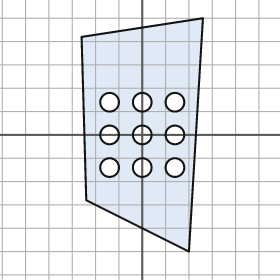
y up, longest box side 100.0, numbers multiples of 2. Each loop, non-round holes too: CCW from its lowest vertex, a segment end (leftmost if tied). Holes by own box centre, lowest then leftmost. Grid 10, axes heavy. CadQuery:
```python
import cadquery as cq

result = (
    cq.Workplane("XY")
    .moveTo(20.0, -50.0)
    .lineTo(26.0, 50.0)
    .lineTo(-26.0, 42.0)
    .lineTo(-24.0, -28.0)
    .close()
    .moveTo(-14.0, -14.0)
    .circle(4.0)
    .moveTo(0.0, -14.0)
    .circle(4.0)
    .moveTo(14.0, -14.0)
    .circle(4.0)
    .moveTo(-14.0, 0.0)
    .circle(4.0)
    .moveTo(0.0, 0.0)
    .circle(4.0)
    .moveTo(14.0, 0.0)
    .circle(4.0)
    .moveTo(-14.0, 14.0)
    .circle(4.0)
    .moveTo(0.0, 14.0)
    .circle(4.0)
    .moveTo(14.0, 14.0)
    .circle(4.0)
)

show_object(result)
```